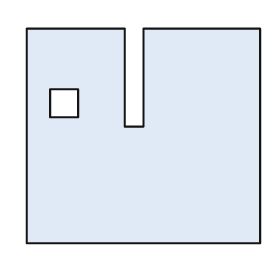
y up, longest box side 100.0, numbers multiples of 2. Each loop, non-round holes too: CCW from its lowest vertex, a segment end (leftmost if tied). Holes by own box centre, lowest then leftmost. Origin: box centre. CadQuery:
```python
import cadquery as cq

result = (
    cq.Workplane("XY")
    .moveTo(-50.0, -46.0)
    .lineTo(50.0, -46.0)
    .lineTo(50.0, 46.0)
    .lineTo(0.0, 46.0)
    .lineTo(0.0, 4.0)
    .lineTo(-8.0, 4.0)
    .lineTo(-8.0, 46.0)
    .lineTo(-50.0, 46.0)
    .close()
    .moveTo(-40.0, 8.0)
    .lineTo(-28.0, 8.0)
    .lineTo(-28.0, 20.0)
    .lineTo(-40.0, 20.0)
    .close()
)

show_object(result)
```